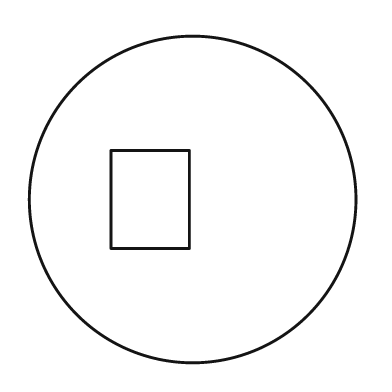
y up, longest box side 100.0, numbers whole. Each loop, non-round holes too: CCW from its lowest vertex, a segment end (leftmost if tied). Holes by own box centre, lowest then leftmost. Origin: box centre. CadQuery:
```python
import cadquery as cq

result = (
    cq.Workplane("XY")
    .moveTo(0.0, 0.0)
    .circle(50.0)
    .moveTo(-25.0, -15.0)
    .lineTo(-1.0, -15.0)
    .lineTo(-1.0, 15.0)
    .lineTo(-25.0, 15.0)
    .close()
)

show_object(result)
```